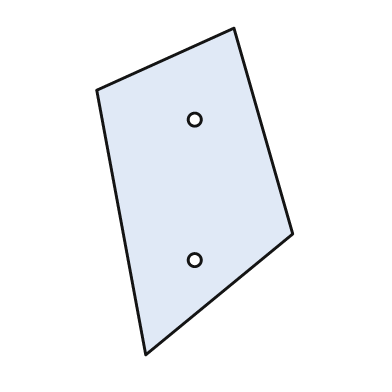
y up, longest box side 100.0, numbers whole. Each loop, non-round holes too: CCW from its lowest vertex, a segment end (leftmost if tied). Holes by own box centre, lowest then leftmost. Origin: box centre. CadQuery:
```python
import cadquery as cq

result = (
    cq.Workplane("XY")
    .moveTo(-15.0, -50.0)
    .lineTo(30.0, -13.0)
    .lineTo(12.0, 50.0)
    .lineTo(-30.0, 31.0)
    .close()
    .moveTo(0.0, -21.0)
    .circle(2.0)
    .moveTo(0.0, 22.0)
    .circle(2.0)
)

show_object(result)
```